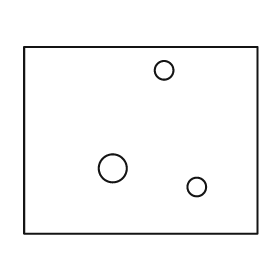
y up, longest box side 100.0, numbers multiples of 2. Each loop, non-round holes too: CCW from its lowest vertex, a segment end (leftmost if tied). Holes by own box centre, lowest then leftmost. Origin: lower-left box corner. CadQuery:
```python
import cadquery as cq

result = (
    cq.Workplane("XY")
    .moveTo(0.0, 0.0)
    .lineTo(100.0, 0.0)
    .lineTo(100.0, 80.0)
    .lineTo(0.0, 80.0)
    .close()
    .moveTo(74.0, 20.0)
    .circle(4.0)
    .moveTo(38.0, 28.0)
    .circle(6.0)
    .moveTo(60.0, 70.0)
    .circle(4.0)
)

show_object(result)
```